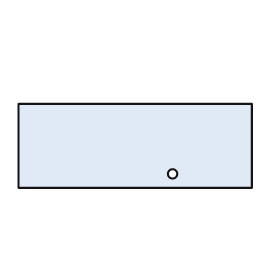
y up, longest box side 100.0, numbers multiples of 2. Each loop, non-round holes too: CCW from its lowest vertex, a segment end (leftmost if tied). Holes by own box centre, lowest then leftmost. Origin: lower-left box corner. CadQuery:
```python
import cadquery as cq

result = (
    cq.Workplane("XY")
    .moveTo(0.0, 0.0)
    .lineTo(100.0, 0.0)
    .lineTo(100.0, 36.0)
    .lineTo(0.0, 36.0)
    .close()
    .moveTo(66.0, 6.0)
    .circle(2.0)
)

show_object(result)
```